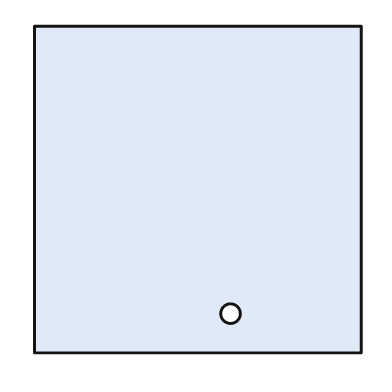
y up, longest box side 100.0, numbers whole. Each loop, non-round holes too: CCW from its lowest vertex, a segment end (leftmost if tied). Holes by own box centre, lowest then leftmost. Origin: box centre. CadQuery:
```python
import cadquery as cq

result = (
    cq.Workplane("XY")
    .moveTo(-50.0, -50.0)
    .lineTo(50.0, -50.0)
    .lineTo(50.0, 50.0)
    .lineTo(-50.0, 50.0)
    .close()
    .moveTo(10.0, -38.0)
    .circle(3.0)
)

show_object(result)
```